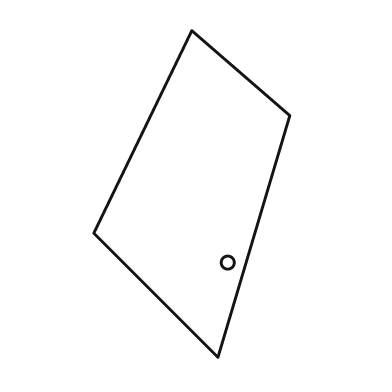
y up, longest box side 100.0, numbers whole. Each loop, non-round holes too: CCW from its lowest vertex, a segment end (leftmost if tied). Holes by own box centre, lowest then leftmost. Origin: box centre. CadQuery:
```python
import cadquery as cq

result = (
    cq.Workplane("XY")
    .moveTo(8.0, -50.0)
    .lineTo(30.0, 24.0)
    .lineTo(0.0, 50.0)
    .lineTo(-30.0, -12.0)
    .close()
    .moveTo(11.0, -21.0)
    .circle(2.0)
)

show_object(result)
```